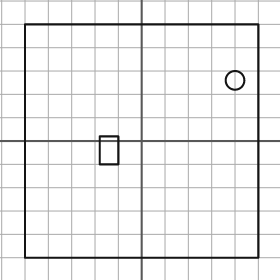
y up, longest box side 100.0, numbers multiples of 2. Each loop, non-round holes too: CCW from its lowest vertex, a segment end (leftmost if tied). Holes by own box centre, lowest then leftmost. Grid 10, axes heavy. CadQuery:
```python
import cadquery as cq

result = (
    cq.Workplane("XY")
    .moveTo(-50.0, -50.0)
    .lineTo(50.0, -50.0)
    .lineTo(50.0, 50.0)
    .lineTo(-50.0, 50.0)
    .close()
    .moveTo(-18.0, -10.0)
    .lineTo(-10.0, -10.0)
    .lineTo(-10.0, 2.0)
    .lineTo(-18.0, 2.0)
    .close()
    .moveTo(40.0, 26.0)
    .circle(4.0)
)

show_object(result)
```